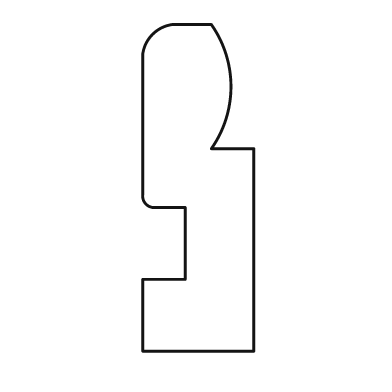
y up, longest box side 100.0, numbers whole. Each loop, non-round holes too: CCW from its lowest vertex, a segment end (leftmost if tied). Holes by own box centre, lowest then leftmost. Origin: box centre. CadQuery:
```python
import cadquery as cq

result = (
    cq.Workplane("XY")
    .moveTo(-17.0, -50.0)
    .lineTo(17.0, -50.0)
    .lineTo(17.0, 12.0)
    .lineTo(4.0, 12.0)
    .threePointArc((10.0, 31.0), (4.0, 50.0))
    .lineTo(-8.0, 50.0)
    .threePointArc((-14.0, 47.0), (-17.0, 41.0))
    .lineTo(-17.0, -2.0)
    .threePointArc((-16.0, -5.0), (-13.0, -6.0))
    .lineTo(-4.0, -6.0)
    .lineTo(-4.0, -28.0)
    .lineTo(-17.0, -28.0)
    .close()
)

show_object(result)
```